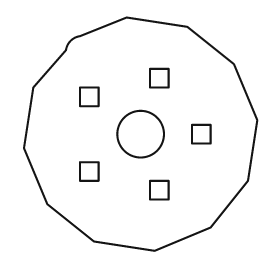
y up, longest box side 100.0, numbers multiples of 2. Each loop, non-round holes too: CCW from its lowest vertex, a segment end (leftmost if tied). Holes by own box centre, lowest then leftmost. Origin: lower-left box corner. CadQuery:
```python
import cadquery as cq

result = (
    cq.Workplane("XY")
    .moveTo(56.0, 0.0)
    .lineTo(80.0, 10.0)
    .lineTo(96.0, 30.0)
    .lineTo(100.0, 56.0)
    .lineTo(90.0, 80.0)
    .lineTo(70.0, 96.0)
    .lineTo(44.0, 100.0)
    .lineTo(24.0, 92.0)
    .threePointArc((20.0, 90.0), (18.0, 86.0))
    .lineTo(4.0, 70.0)
    .lineTo(0.0, 44.0)
    .lineTo(10.0, 20.0)
    .lineTo(30.0, 4.0)
    .close()
    .moveTo(54.0, 22.0)
    .lineTo(62.0, 22.0)
    .lineTo(62.0, 30.0)
    .lineTo(54.0, 30.0)
    .close()
    .moveTo(24.0, 30.0)
    .lineTo(32.0, 30.0)
    .lineTo(32.0, 38.0)
    .lineTo(24.0, 38.0)
    .close()
    .moveTo(50.0, 50.0)
    .circle(10.0)
    .moveTo(72.0, 46.0)
    .lineTo(80.0, 46.0)
    .lineTo(80.0, 54.0)
    .lineTo(72.0, 54.0)
    .close()
    .moveTo(24.0, 62.0)
    .lineTo(32.0, 62.0)
    .lineTo(32.0, 70.0)
    .lineTo(24.0, 70.0)
    .close()
    .moveTo(54.0, 70.0)
    .lineTo(62.0, 70.0)
    .lineTo(62.0, 78.0)
    .lineTo(54.0, 78.0)
    .close()
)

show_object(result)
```